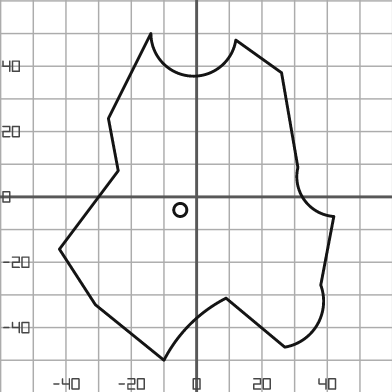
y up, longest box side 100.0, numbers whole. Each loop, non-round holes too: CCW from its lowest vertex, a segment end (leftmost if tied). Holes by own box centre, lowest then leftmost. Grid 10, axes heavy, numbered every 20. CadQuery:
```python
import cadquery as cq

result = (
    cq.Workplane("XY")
    .moveTo(-10.0, -50.0)
    .threePointArc((-2.0, -39.0), (9.0, -31.0))
    .lineTo(27.0, -46.0)
    .threePointArc((37.0, -39.0), (38.0, -27.0))
    .lineTo(42.0, -6.0)
    .threePointArc((33.0, -1.0), (31.0, 9.0))
    .lineTo(26.0, 38.0)
    .lineTo(12.0, 48.0)
    .threePointArc((-2.0, 37.0), (-14.0, 50.0))
    .lineTo(-27.0, 24.0)
    .lineTo(-24.0, 8.0)
    .lineTo(-42.0, -16.0)
    .lineTo(-31.0, -33.0)
    .close()
    .moveTo(-5.0, -4.0)
    .circle(2.0)
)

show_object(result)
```